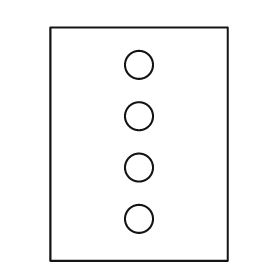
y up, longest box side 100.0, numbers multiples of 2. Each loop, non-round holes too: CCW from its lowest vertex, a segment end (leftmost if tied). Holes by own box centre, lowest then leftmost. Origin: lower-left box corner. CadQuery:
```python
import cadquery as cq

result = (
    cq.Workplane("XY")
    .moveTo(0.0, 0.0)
    .lineTo(76.0, 0.0)
    .lineTo(76.0, 100.0)
    .lineTo(0.0, 100.0)
    .close()
    .moveTo(38.0, 18.0)
    .circle(6.0)
    .moveTo(38.0, 40.0)
    .circle(6.0)
    .moveTo(38.0, 62.0)
    .circle(6.0)
    .moveTo(38.0, 84.0)
    .circle(6.0)
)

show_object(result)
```